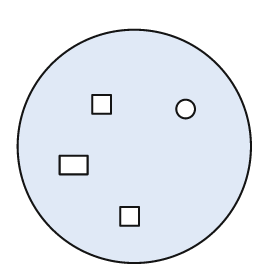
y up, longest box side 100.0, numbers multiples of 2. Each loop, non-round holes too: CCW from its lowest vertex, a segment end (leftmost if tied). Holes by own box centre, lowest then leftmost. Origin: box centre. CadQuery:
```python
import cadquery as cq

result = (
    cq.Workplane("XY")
    .moveTo(0.0, 0.0)
    .circle(50.0)
    .moveTo(-6.0, -34.0)
    .lineTo(2.0, -34.0)
    .lineTo(2.0, -26.0)
    .lineTo(-6.0, -26.0)
    .close()
    .moveTo(-32.0, -12.0)
    .lineTo(-20.0, -12.0)
    .lineTo(-20.0, -4.0)
    .lineTo(-32.0, -4.0)
    .close()
    .moveTo(22.0, 16.0)
    .circle(4.0)
    .moveTo(-18.0, 14.0)
    .lineTo(-10.0, 14.0)
    .lineTo(-10.0, 22.0)
    .lineTo(-18.0, 22.0)
    .close()
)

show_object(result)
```